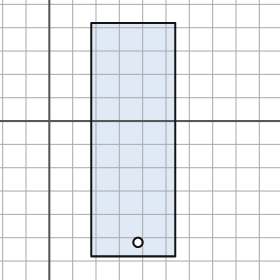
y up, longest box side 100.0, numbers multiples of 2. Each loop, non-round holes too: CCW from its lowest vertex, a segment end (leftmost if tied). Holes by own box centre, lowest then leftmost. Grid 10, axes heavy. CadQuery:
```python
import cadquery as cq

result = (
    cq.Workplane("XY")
    .moveTo(18.0, -58.0)
    .lineTo(54.0, -58.0)
    .lineTo(54.0, 42.0)
    .lineTo(18.0, 42.0)
    .close()
    .moveTo(38.0, -52.0)
    .circle(2.0)
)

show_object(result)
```